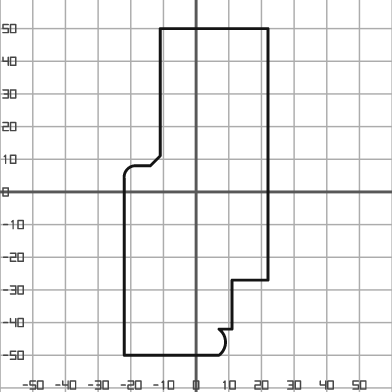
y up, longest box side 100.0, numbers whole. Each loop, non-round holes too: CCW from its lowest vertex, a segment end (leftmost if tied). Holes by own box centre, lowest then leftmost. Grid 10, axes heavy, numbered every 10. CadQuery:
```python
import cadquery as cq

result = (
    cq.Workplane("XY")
    .moveTo(-22.0, -50.0)
    .lineTo(7.0, -50.0)
    .threePointArc((9.0, -46.0), (7.0, -42.0))
    .lineTo(11.0, -42.0)
    .lineTo(11.0, -27.0)
    .lineTo(22.0, -27.0)
    .lineTo(22.0, 50.0)
    .lineTo(-11.0, 50.0)
    .lineTo(-11.0, 11.0)
    .lineTo(-14.0, 8.0)
    .lineTo(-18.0, 8.0)
    .threePointArc((-21.0, 7.0), (-22.0, 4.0))
    .close()
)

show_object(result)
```